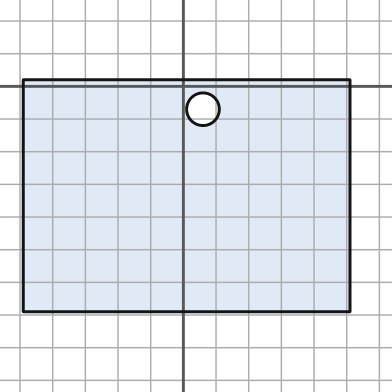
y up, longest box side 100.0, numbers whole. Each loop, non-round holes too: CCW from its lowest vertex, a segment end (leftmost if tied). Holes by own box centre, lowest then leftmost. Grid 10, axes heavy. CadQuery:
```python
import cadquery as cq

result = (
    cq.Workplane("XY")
    .moveTo(-49.0, -69.0)
    .lineTo(51.0, -69.0)
    .lineTo(51.0, 2.0)
    .lineTo(-49.0, 2.0)
    .close()
    .moveTo(6.0, -7.0)
    .circle(5.0)
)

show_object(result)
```